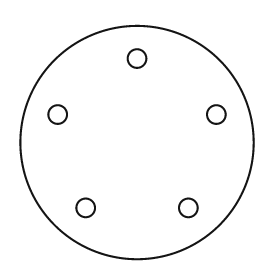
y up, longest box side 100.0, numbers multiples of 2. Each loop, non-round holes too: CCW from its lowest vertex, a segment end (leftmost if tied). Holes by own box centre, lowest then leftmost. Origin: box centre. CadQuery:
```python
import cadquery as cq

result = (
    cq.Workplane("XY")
    .moveTo(0.0, 0.0)
    .circle(50.0)
    .moveTo(-22.0, -28.0)
    .circle(4.0)
    .moveTo(22.0, -28.0)
    .circle(4.0)
    .moveTo(-34.0, 12.0)
    .circle(4.0)
    .moveTo(34.0, 12.0)
    .circle(4.0)
    .moveTo(0.0, 36.0)
    .circle(4.0)
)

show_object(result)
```